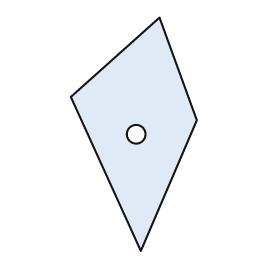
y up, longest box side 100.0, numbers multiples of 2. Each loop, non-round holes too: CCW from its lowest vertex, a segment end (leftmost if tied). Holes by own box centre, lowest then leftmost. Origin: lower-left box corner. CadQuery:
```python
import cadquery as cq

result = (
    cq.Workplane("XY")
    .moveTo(30.0, 0.0)
    .lineTo(54.0, 56.0)
    .lineTo(38.0, 100.0)
    .lineTo(0.0, 66.0)
    .close()
    .moveTo(28.0, 50.0)
    .circle(4.0)
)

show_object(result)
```